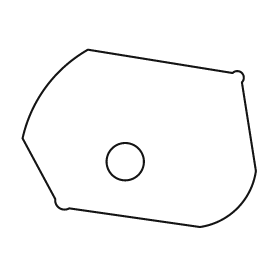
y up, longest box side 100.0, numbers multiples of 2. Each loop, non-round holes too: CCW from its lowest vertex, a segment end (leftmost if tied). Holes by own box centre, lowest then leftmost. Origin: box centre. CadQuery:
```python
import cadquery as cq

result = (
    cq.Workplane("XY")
    .moveTo(26.0, -38.0)
    .threePointArc((42.0, -30.0), (50.0, -14.0))
    .lineTo(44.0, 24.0)
    .threePointArc((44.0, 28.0), (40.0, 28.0))
    .lineTo(-22.0, 38.0)
    .threePointArc((-40.0, 22.0), (-50.0, 0.0))
    .lineTo(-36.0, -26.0)
    .threePointArc((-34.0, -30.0), (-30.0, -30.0))
    .close()
    .moveTo(-6.0, -10.0)
    .circle(8.0)
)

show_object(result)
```